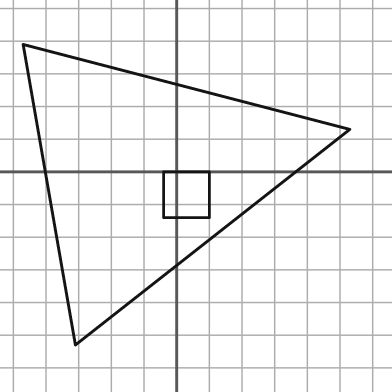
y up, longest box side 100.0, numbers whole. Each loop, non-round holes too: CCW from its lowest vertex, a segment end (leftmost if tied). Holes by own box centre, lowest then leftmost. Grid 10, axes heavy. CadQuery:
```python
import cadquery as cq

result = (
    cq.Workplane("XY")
    .moveTo(-31.0, -53.0)
    .lineTo(53.0, 13.0)
    .lineTo(-47.0, 39.0)
    .close()
    .moveTo(-4.0, -14.0)
    .lineTo(10.0, -14.0)
    .lineTo(10.0, 0.0)
    .lineTo(-4.0, 0.0)
    .close()
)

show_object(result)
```